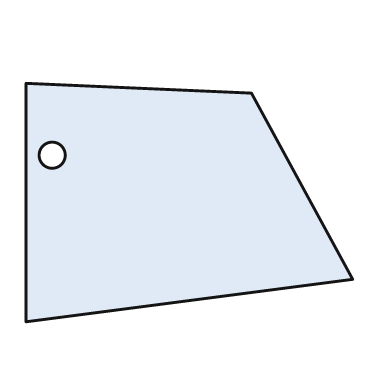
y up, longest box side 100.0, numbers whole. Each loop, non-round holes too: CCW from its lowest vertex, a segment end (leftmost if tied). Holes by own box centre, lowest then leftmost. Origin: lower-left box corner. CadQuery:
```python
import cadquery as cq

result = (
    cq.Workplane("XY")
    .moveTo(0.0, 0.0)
    .lineTo(100.0, 13.0)
    .lineTo(69.0, 70.0)
    .lineTo(0.0, 73.0)
    .close()
    .moveTo(8.0, 51.0)
    .circle(4.0)
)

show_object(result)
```